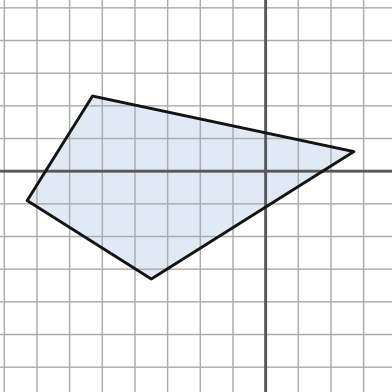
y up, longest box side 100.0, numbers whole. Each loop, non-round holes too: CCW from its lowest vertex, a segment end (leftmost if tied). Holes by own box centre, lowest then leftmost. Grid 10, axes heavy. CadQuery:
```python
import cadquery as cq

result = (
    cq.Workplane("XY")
    .moveTo(-35.0, -33.0)
    .lineTo(27.0, 6.0)
    .lineTo(-53.0, 23.0)
    .lineTo(-73.0, -9.0)
    .close()
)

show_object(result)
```